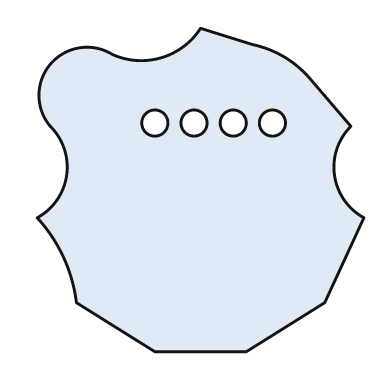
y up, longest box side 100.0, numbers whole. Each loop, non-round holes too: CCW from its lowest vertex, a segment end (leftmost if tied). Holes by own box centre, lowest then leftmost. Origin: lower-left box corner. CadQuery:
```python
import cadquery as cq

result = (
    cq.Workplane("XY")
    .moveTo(36.0, 0.0)
    .lineTo(64.0, 0.0)
    .lineTo(88.0, 15.0)
    .lineTo(100.0, 41.0)
    .threePointArc((91.0, 54.0), (96.0, 69.0))
    .lineTo(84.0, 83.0)
    .threePointArc((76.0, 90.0), (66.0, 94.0))
    .lineTo(50.0, 99.0)
    .threePointArc((38.0, 90.0), (23.0, 91.0))
    .threePointArc((4.0, 88.0), (4.0, 69.0))
    .threePointArc((9.0, 54.0), (0.0, 41.0))
    .threePointArc((8.0, 29.0), (12.0, 15.0))
    .close()
    .moveTo(36.0, 70.0)
    .circle(4.0)
    .moveTo(48.0, 70.0)
    .circle(4.0)
    .moveTo(60.0, 70.0)
    .circle(4.0)
    .moveTo(72.0, 70.0)
    .circle(4.0)
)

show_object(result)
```